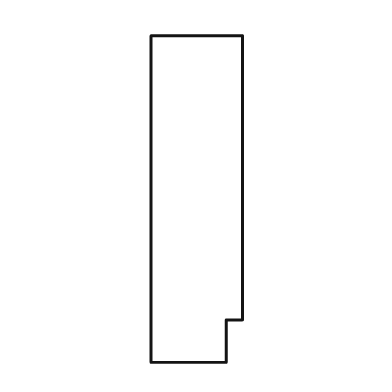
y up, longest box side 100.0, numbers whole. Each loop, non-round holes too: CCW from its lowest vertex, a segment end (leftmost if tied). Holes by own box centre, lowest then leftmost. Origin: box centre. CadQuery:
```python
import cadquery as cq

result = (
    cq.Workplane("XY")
    .moveTo(-14.0, -50.0)
    .lineTo(9.0, -50.0)
    .lineTo(9.0, -37.0)
    .lineTo(14.0, -37.0)
    .lineTo(14.0, 50.0)
    .lineTo(-14.0, 50.0)
    .close()
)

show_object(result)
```